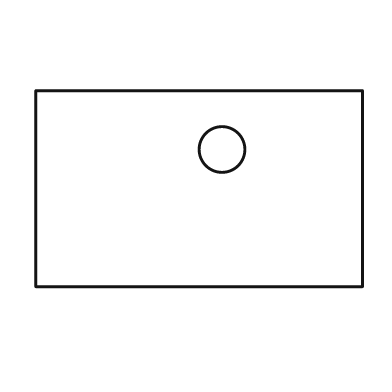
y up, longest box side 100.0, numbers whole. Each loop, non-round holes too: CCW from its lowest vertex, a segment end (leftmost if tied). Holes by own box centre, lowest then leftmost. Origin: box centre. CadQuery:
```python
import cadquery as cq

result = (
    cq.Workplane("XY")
    .moveTo(-50.0, -30.0)
    .lineTo(50.0, -30.0)
    .lineTo(50.0, 30.0)
    .lineTo(-50.0, 30.0)
    .close()
    .moveTo(7.0, 12.0)
    .circle(7.0)
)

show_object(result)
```